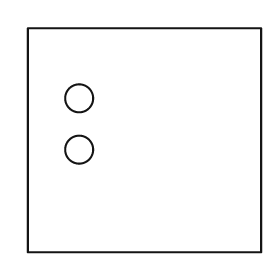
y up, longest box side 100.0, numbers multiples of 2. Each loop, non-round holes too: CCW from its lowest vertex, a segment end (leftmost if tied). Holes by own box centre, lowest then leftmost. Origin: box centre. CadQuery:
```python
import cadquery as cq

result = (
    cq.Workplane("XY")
    .moveTo(-50.0, -48.0)
    .lineTo(50.0, -48.0)
    .lineTo(50.0, 48.0)
    .lineTo(-50.0, 48.0)
    .close()
    .moveTo(-28.0, -4.0)
    .circle(6.0)
    .moveTo(-28.0, 18.0)
    .circle(6.0)
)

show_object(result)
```